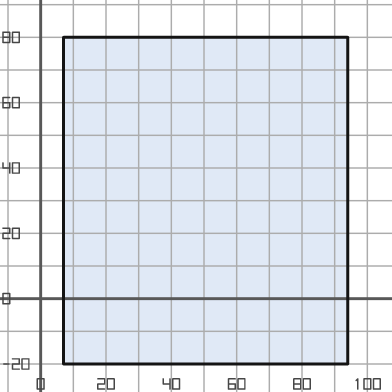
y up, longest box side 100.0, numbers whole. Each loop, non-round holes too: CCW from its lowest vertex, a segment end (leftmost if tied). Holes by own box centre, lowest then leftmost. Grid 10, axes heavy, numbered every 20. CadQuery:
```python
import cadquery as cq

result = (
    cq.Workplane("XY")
    .moveTo(7.0, -20.0)
    .lineTo(94.0, -20.0)
    .lineTo(94.0, 80.0)
    .lineTo(7.0, 80.0)
    .close()
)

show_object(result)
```